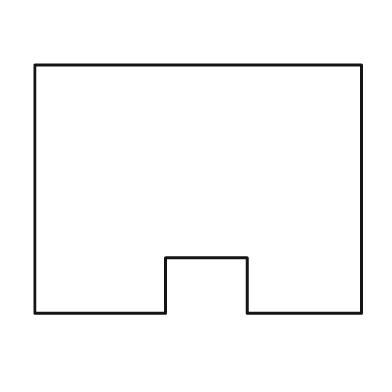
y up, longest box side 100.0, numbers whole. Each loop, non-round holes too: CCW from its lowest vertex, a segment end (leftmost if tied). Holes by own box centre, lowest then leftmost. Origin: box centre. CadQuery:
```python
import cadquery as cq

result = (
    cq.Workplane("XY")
    .moveTo(-50.0, -38.0)
    .lineTo(-10.0, -38.0)
    .lineTo(-10.0, -21.0)
    .lineTo(15.0, -21.0)
    .lineTo(15.0, -38.0)
    .lineTo(50.0, -38.0)
    .lineTo(50.0, 38.0)
    .lineTo(-50.0, 38.0)
    .close()
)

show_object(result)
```